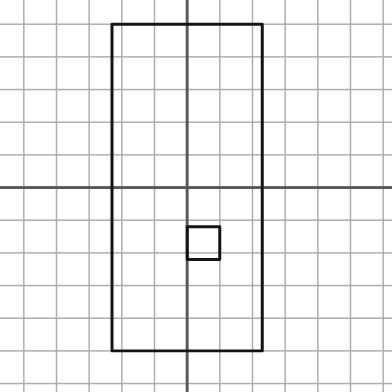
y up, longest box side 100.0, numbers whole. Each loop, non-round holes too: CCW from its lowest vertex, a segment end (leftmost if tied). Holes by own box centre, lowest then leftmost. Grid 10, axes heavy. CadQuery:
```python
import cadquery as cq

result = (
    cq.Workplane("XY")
    .moveTo(-23.0, -50.0)
    .lineTo(23.0, -50.0)
    .lineTo(23.0, 50.0)
    .lineTo(-23.0, 50.0)
    .close()
    .moveTo(0.0, -22.0)
    .lineTo(10.0, -22.0)
    .lineTo(10.0, -12.0)
    .lineTo(0.0, -12.0)
    .close()
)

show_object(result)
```